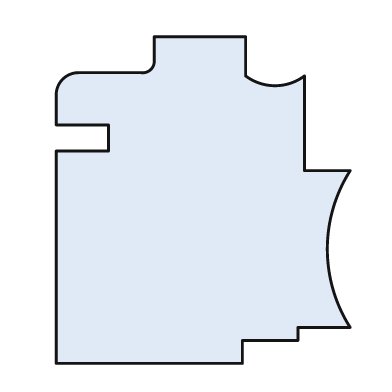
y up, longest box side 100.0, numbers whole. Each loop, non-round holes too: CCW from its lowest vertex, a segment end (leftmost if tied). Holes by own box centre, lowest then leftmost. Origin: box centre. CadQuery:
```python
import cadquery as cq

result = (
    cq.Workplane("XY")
    .moveTo(-45.0, -50.0)
    .lineTo(12.0, -50.0)
    .lineTo(12.0, -43.0)
    .lineTo(29.0, -43.0)
    .lineTo(29.0, -39.0)
    .lineTo(45.0, -39.0)
    .threePointArc((38.0, -15.0), (45.0, 9.0))
    .lineTo(31.0, 9.0)
    .lineTo(31.0, 38.0)
    .threePointArc((22.0, 35.0), (13.0, 38.0))
    .lineTo(13.0, 50.0)
    .lineTo(-15.0, 50.0)
    .lineTo(-15.0, 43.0)
    .threePointArc((-16.0, 40.0), (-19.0, 39.0))
    .lineTo(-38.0, 39.0)
    .threePointArc((-43.0, 37.0), (-45.0, 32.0))
    .lineTo(-45.0, 23.0)
    .lineTo(-29.0, 23.0)
    .lineTo(-29.0, 15.0)
    .lineTo(-45.0, 15.0)
    .close()
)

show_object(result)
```